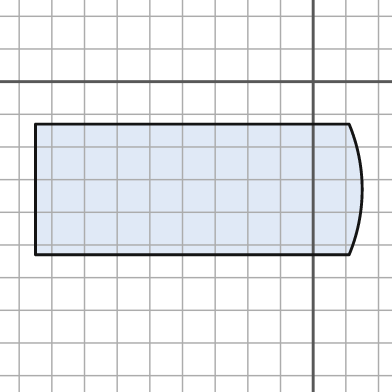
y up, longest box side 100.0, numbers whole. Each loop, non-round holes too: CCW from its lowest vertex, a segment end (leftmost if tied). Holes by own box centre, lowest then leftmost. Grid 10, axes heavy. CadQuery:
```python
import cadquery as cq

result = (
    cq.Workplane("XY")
    .moveTo(-85.0, -53.0)
    .lineTo(11.0, -53.0)
    .threePointArc((15.0, -33.0), (11.0, -13.0))
    .lineTo(-85.0, -13.0)
    .close()
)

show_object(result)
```